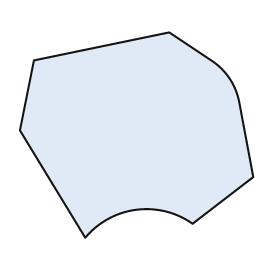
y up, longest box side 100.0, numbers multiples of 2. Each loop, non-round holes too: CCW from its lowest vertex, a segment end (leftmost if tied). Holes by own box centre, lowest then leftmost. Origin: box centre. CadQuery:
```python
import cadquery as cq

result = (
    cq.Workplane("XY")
    .moveTo(-22.0, -44.0)
    .threePointArc((0.0, -32.0), (24.0, -38.0))
    .lineTo(50.0, -18.0)
    .lineTo(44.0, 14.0)
    .threePointArc((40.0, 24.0), (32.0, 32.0))
    .lineTo(14.0, 44.0)
    .lineTo(-44.0, 32.0)
    .lineTo(-50.0, 2.0)
    .close()
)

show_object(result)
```